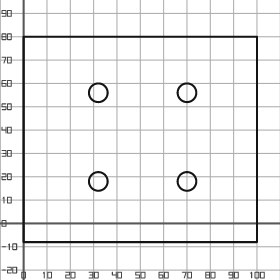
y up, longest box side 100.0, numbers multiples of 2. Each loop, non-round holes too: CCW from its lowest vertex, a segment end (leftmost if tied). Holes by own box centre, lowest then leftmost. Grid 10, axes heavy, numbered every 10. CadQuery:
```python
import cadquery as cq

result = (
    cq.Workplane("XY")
    .moveTo(0.0, -8.0)
    .lineTo(100.0, -8.0)
    .lineTo(100.0, 80.0)
    .lineTo(0.0, 80.0)
    .close()
    .moveTo(32.0, 18.0)
    .circle(4.0)
    .moveTo(70.0, 18.0)
    .circle(4.0)
    .moveTo(32.0, 56.0)
    .circle(4.0)
    .moveTo(70.0, 56.0)
    .circle(4.0)
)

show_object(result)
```